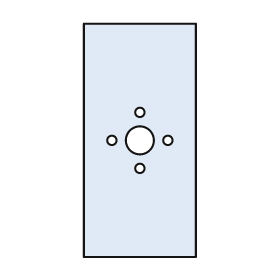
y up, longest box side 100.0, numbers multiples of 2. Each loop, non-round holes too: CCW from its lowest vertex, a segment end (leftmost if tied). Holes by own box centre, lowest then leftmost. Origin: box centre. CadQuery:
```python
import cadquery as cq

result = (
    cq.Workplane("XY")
    .moveTo(-24.0, -50.0)
    .lineTo(24.0, -50.0)
    .lineTo(24.0, 50.0)
    .lineTo(-24.0, 50.0)
    .close()
    .moveTo(0.0, -12.0)
    .circle(2.0)
    .moveTo(-12.0, 0.0)
    .circle(2.0)
    .moveTo(0.0, 0.0)
    .circle(6.0)
    .moveTo(12.0, 0.0)
    .circle(2.0)
    .moveTo(0.0, 12.0)
    .circle(2.0)
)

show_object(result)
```